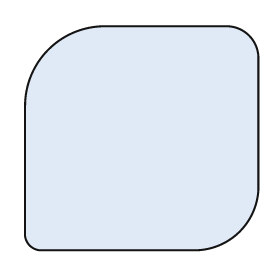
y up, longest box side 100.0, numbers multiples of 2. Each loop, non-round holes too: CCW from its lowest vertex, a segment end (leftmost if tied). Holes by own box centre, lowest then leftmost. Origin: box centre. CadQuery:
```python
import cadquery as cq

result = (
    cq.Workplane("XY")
    .moveTo(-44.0, -48.0)
    .lineTo(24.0, -48.0)
    .threePointArc((42.0, -40.0), (50.0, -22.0))
    .lineTo(50.0, 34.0)
    .threePointArc((46.0, 44.0), (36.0, 48.0))
    .lineTo(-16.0, 48.0)
    .threePointArc((-40.0, 38.0), (-50.0, 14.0))
    .lineTo(-50.0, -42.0)
    .threePointArc((-48.0, -46.0), (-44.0, -48.0))
    .close()
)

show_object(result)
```